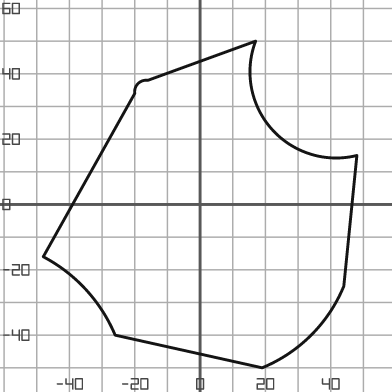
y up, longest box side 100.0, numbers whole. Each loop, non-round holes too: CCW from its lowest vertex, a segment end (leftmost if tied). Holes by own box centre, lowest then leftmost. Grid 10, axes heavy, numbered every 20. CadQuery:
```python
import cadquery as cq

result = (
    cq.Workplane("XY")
    .moveTo(19.0, -50.0)
    .threePointArc((34.0, -40.0), (44.0, -25.0))
    .lineTo(48.0, 15.0)
    .threePointArc((22.0, 23.0), (17.0, 50.0))
    .lineTo(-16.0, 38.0)
    .threePointArc((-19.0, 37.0), (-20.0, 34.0))
    .lineTo(-48.0, -16.0)
    .threePointArc((-35.0, -26.0), (-26.0, -40.0))
    .close()
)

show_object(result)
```